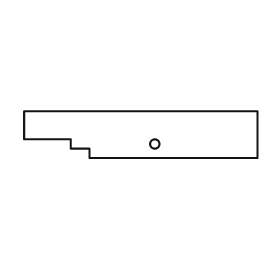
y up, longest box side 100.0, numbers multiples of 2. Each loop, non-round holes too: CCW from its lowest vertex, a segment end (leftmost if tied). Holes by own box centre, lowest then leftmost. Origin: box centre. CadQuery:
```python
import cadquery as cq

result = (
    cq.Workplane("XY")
    .moveTo(-22.0, -10.0)
    .lineTo(50.0, -10.0)
    .lineTo(50.0, 10.0)
    .lineTo(-50.0, 10.0)
    .lineTo(-50.0, -2.0)
    .lineTo(-30.0, -2.0)
    .lineTo(-30.0, -6.0)
    .lineTo(-22.0, -6.0)
    .close()
    .moveTo(6.0, -4.0)
    .circle(2.0)
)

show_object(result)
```